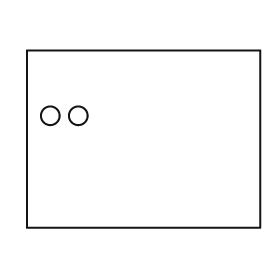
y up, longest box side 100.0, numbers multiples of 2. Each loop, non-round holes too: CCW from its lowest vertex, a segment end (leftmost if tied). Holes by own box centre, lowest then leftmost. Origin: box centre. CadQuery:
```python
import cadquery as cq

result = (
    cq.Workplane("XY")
    .moveTo(-50.0, -38.0)
    .lineTo(50.0, -38.0)
    .lineTo(50.0, 38.0)
    .lineTo(-50.0, 38.0)
    .close()
    .moveTo(-40.0, 10.0)
    .circle(4.0)
    .moveTo(-28.0, 10.0)
    .circle(4.0)
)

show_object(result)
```